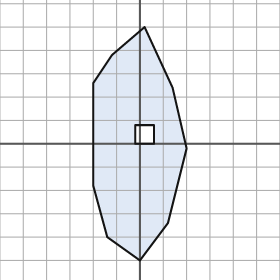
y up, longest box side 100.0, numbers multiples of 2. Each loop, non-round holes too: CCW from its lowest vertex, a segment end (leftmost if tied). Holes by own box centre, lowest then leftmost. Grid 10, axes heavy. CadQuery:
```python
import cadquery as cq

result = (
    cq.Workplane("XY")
    .moveTo(0.0, -50.0)
    .lineTo(12.0, -34.0)
    .lineTo(20.0, -2.0)
    .lineTo(14.0, 24.0)
    .lineTo(2.0, 50.0)
    .lineTo(-12.0, 38.0)
    .lineTo(-20.0, 26.0)
    .lineTo(-20.0, -18.0)
    .lineTo(-14.0, -40.0)
    .close()
    .moveTo(-2.0, 0.0)
    .lineTo(6.0, 0.0)
    .lineTo(6.0, 8.0)
    .lineTo(-2.0, 8.0)
    .close()
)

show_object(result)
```